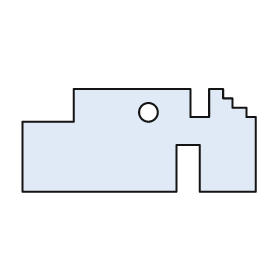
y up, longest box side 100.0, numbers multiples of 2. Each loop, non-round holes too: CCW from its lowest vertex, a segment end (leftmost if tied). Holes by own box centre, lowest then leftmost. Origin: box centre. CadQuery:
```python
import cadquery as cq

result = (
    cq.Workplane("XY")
    .moveTo(-50.0, -22.0)
    .lineTo(16.0, -22.0)
    .lineTo(16.0, -2.0)
    .lineTo(26.0, -2.0)
    .lineTo(26.0, -22.0)
    .lineTo(50.0, -22.0)
    .lineTo(50.0, 10.0)
    .lineTo(46.0, 10.0)
    .lineTo(46.0, 14.0)
    .lineTo(40.0, 14.0)
    .lineTo(40.0, 18.0)
    .lineTo(36.0, 18.0)
    .lineTo(36.0, 22.0)
    .lineTo(30.0, 22.0)
    .lineTo(30.0, 10.0)
    .lineTo(22.0, 10.0)
    .lineTo(22.0, 22.0)
    .lineTo(-28.0, 22.0)
    .lineTo(-28.0, 8.0)
    .lineTo(-50.0, 8.0)
    .close()
    .moveTo(4.0, 12.0)
    .circle(4.0)
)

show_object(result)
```